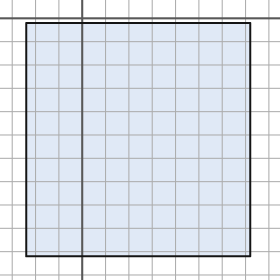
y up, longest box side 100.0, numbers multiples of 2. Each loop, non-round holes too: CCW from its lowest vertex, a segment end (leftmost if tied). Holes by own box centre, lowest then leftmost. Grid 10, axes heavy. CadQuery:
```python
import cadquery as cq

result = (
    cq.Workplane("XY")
    .moveTo(-24.0, -102.0)
    .lineTo(72.0, -102.0)
    .lineTo(72.0, -2.0)
    .lineTo(-24.0, -2.0)
    .close()
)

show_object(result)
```